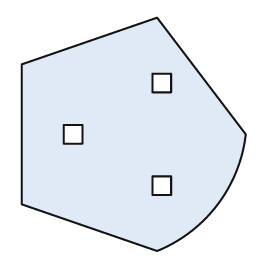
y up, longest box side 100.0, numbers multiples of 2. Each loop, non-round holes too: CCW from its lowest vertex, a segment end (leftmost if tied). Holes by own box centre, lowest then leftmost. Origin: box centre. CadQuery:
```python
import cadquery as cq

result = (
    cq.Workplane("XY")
    .moveTo(10.0, -50.0)
    .threePointArc((36.0, -30.0), (48.0, 0.0))
    .lineTo(10.0, 50.0)
    .lineTo(-48.0, 30.0)
    .lineTo(-48.0, -30.0)
    .close()
    .moveTo(8.0, -26.0)
    .lineTo(16.0, -26.0)
    .lineTo(16.0, -18.0)
    .lineTo(8.0, -18.0)
    .close()
    .moveTo(-30.0, -4.0)
    .lineTo(-22.0, -4.0)
    .lineTo(-22.0, 4.0)
    .lineTo(-30.0, 4.0)
    .close()
    .moveTo(8.0, 18.0)
    .lineTo(16.0, 18.0)
    .lineTo(16.0, 26.0)
    .lineTo(8.0, 26.0)
    .close()
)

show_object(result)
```